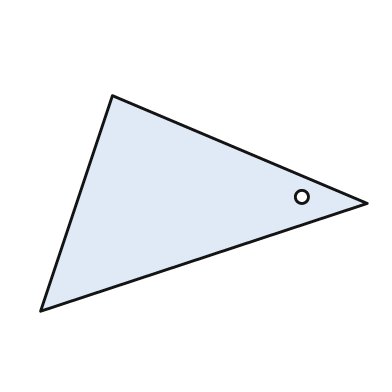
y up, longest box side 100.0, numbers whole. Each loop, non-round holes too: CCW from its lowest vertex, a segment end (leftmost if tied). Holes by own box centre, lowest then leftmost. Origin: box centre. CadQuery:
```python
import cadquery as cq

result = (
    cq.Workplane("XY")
    .moveTo(-50.0, -33.0)
    .lineTo(50.0, 0.0)
    .lineTo(-28.0, 33.0)
    .close()
    .moveTo(30.0, 2.0)
    .circle(2.0)
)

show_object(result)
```